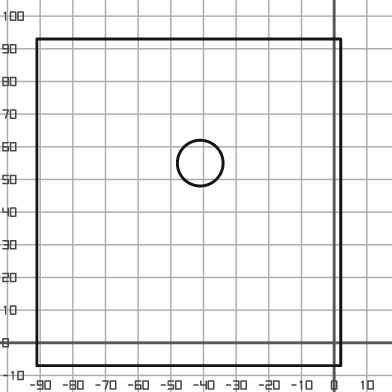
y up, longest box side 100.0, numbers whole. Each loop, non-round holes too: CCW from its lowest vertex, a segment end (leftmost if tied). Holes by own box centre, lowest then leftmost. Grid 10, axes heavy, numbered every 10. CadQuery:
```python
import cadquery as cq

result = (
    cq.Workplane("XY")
    .moveTo(-91.0, -7.0)
    .lineTo(2.0, -7.0)
    .lineTo(2.0, 93.0)
    .lineTo(-91.0, 93.0)
    .close()
    .moveTo(-41.0, 55.0)
    .circle(7.0)
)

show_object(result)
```